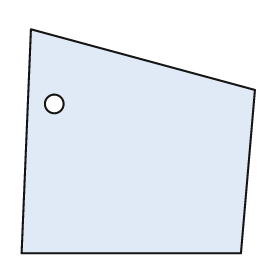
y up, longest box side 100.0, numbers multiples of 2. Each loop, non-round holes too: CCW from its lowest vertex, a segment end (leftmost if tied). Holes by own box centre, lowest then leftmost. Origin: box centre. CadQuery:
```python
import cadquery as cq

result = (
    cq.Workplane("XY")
    .moveTo(-50.0, -48.0)
    .lineTo(44.0, -48.0)
    .lineTo(50.0, 22.0)
    .lineTo(-46.0, 48.0)
    .close()
    .moveTo(-36.0, 16.0)
    .circle(4.0)
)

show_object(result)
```